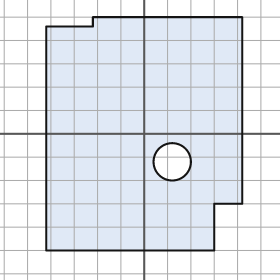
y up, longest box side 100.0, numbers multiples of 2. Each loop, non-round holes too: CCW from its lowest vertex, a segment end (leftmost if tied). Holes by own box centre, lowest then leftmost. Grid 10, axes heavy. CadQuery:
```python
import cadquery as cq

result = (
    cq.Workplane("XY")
    .moveTo(-42.0, -50.0)
    .lineTo(30.0, -50.0)
    .lineTo(30.0, -30.0)
    .lineTo(42.0, -30.0)
    .lineTo(42.0, 50.0)
    .lineTo(-22.0, 50.0)
    .lineTo(-22.0, 46.0)
    .lineTo(-42.0, 46.0)
    .close()
    .moveTo(12.0, -12.0)
    .circle(8.0)
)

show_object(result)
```